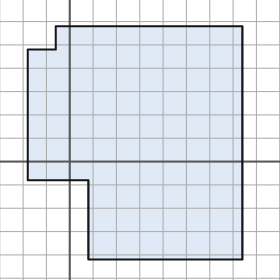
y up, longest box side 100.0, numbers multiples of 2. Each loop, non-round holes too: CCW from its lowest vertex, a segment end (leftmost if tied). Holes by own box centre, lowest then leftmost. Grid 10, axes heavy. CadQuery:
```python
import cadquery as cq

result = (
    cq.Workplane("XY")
    .moveTo(8.0, -42.0)
    .lineTo(74.0, -42.0)
    .lineTo(74.0, 58.0)
    .lineTo(-6.0, 58.0)
    .lineTo(-6.0, 48.0)
    .lineTo(-18.0, 48.0)
    .lineTo(-18.0, -8.0)
    .lineTo(8.0, -8.0)
    .close()
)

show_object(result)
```